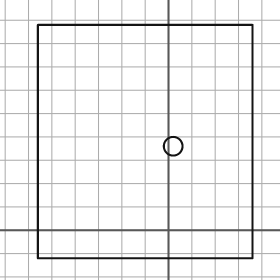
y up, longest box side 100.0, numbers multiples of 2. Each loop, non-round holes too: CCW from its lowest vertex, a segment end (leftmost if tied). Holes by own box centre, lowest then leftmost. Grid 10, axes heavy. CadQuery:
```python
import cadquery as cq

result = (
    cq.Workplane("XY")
    .moveTo(-56.0, -12.0)
    .lineTo(36.0, -12.0)
    .lineTo(36.0, 88.0)
    .lineTo(-56.0, 88.0)
    .close()
    .moveTo(2.0, 36.0)
    .circle(4.0)
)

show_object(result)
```